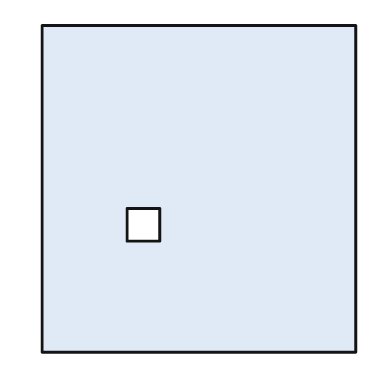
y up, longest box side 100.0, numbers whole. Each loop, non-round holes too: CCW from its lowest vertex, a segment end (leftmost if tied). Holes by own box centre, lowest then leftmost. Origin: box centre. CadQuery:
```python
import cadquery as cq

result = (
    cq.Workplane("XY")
    .moveTo(-48.0, -50.0)
    .lineTo(48.0, -50.0)
    .lineTo(48.0, 50.0)
    .lineTo(-48.0, 50.0)
    .close()
    .moveTo(-22.0, -16.0)
    .lineTo(-12.0, -16.0)
    .lineTo(-12.0, -6.0)
    .lineTo(-22.0, -6.0)
    .close()
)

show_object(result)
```